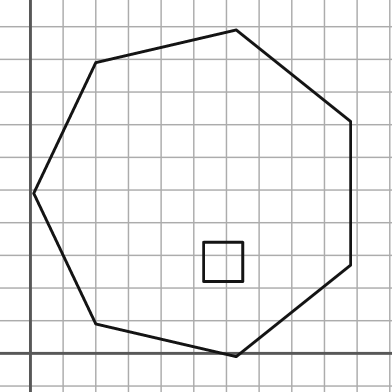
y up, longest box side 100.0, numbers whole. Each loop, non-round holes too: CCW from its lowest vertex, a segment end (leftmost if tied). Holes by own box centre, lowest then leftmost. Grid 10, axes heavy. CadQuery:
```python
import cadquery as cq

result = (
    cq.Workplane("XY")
    .moveTo(63.0, -1.0)
    .lineTo(98.0, 27.0)
    .lineTo(98.0, 71.0)
    .lineTo(63.0, 99.0)
    .lineTo(20.0, 89.0)
    .lineTo(1.0, 49.0)
    .lineTo(20.0, 9.0)
    .close()
    .moveTo(53.0, 22.0)
    .lineTo(65.0, 22.0)
    .lineTo(65.0, 34.0)
    .lineTo(53.0, 34.0)
    .close()
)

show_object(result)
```